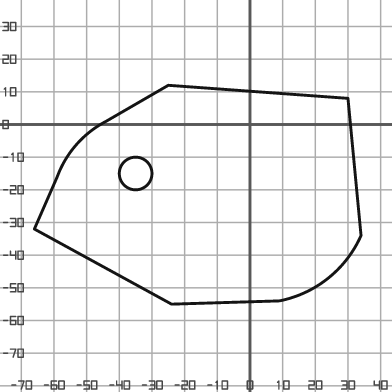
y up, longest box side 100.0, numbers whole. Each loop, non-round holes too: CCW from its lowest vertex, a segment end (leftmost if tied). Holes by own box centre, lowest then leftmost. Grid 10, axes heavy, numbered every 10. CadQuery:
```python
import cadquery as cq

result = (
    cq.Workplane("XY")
    .moveTo(-24.0, -55.0)
    .lineTo(9.0, -54.0)
    .threePointArc((24.0, -47.0), (34.0, -34.0))
    .lineTo(30.0, 8.0)
    .lineTo(-25.0, 12.0)
    .lineTo(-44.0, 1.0)
    .threePointArc((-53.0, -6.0), (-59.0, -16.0))
    .lineTo(-66.0, -32.0)
    .close()
    .moveTo(-35.0, -15.0)
    .circle(5.0)
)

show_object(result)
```